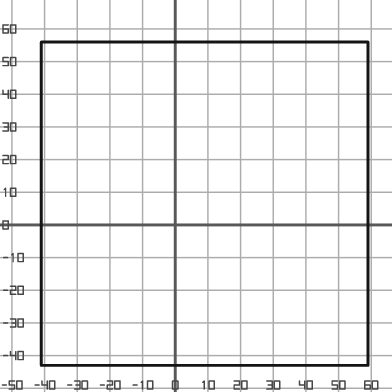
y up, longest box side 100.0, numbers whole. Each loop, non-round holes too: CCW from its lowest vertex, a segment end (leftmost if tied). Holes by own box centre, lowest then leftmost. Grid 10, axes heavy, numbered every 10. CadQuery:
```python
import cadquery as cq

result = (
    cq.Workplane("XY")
    .moveTo(-41.0, -43.0)
    .lineTo(59.0, -43.0)
    .lineTo(59.0, 56.0)
    .lineTo(-41.0, 56.0)
    .close()
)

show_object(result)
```